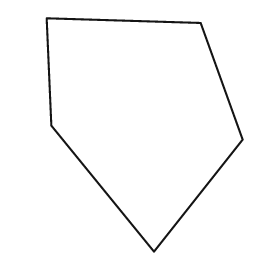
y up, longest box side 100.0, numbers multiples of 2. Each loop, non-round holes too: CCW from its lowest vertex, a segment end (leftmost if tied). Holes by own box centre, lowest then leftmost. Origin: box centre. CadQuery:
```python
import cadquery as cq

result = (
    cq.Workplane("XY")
    .moveTo(4.0, -50.0)
    .lineTo(42.0, -2.0)
    .lineTo(24.0, 48.0)
    .lineTo(-42.0, 50.0)
    .lineTo(-40.0, 4.0)
    .close()
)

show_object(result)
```